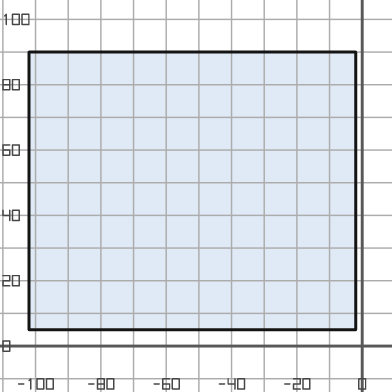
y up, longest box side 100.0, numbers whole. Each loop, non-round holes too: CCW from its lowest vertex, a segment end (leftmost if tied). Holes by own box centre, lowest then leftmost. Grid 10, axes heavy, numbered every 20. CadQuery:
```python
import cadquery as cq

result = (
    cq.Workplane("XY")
    .moveTo(-102.0, 5.0)
    .lineTo(-2.0, 5.0)
    .lineTo(-2.0, 90.0)
    .lineTo(-102.0, 90.0)
    .close()
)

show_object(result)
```